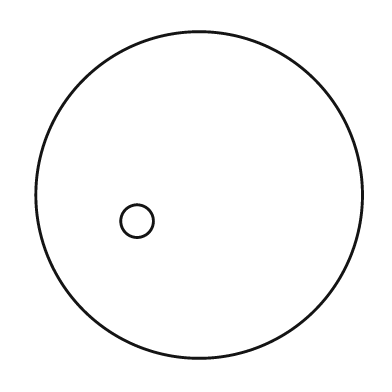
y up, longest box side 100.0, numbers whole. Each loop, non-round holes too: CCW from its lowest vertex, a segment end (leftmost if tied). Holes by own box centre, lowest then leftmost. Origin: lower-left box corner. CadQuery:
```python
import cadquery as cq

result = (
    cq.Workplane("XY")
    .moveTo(50.0, 50.0)
    .circle(50.0)
    .moveTo(31.0, 42.0)
    .circle(5.0)
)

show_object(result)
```